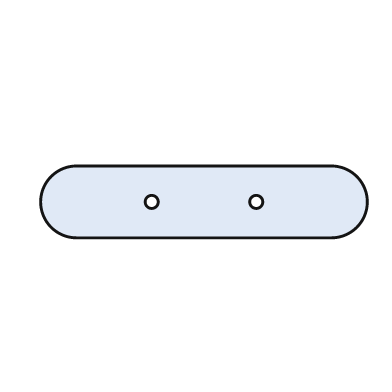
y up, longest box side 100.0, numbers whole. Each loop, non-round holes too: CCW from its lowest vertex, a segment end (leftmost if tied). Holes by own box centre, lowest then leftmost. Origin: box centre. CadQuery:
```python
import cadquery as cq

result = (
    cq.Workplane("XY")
    .moveTo(-39.0, -11.0)
    .lineTo(39.0, -11.0)
    .threePointArc((50.0, 0.0), (39.0, 11.0))
    .lineTo(-39.0, 11.0)
    .threePointArc((-50.0, 0.0), (-39.0, -11.0))
    .close()
    .moveTo(-16.0, 0.0)
    .circle(2.0)
    .moveTo(16.0, 0.0)
    .circle(2.0)
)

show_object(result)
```